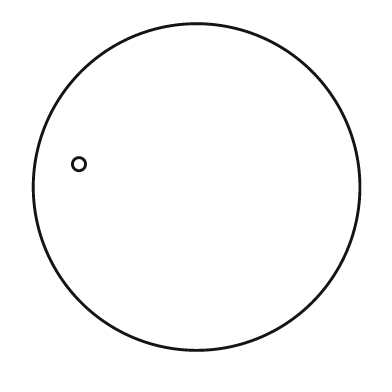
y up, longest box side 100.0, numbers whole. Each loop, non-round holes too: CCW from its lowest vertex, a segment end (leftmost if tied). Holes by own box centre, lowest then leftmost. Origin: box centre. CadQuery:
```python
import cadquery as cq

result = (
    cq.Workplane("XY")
    .moveTo(0.0, 0.0)
    .circle(50.0)
    .moveTo(-36.0, 7.0)
    .circle(2.0)
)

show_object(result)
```